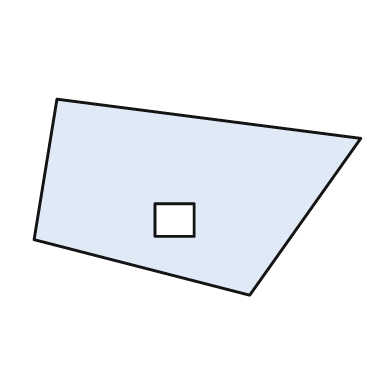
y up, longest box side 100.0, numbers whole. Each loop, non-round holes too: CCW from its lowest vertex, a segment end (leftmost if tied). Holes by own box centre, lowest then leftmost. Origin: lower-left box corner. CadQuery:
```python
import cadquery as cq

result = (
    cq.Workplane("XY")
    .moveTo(66.0, 0.0)
    .lineTo(100.0, 48.0)
    .lineTo(7.0, 60.0)
    .lineTo(0.0, 17.0)
    .close()
    .moveTo(37.0, 18.0)
    .lineTo(49.0, 18.0)
    .lineTo(49.0, 28.0)
    .lineTo(37.0, 28.0)
    .close()
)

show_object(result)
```